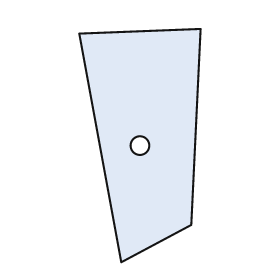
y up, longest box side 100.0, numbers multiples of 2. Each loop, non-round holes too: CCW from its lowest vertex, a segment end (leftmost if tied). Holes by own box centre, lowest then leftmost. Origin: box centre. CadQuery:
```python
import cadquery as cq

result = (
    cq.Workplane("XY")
    .moveTo(-8.0, -50.0)
    .lineTo(22.0, -34.0)
    .lineTo(26.0, 50.0)
    .lineTo(-26.0, 48.0)
    .close()
    .moveTo(0.0, 0.0)
    .circle(4.0)
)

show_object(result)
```